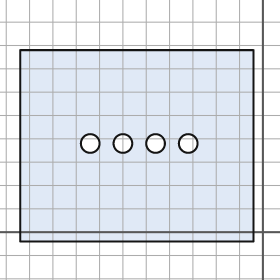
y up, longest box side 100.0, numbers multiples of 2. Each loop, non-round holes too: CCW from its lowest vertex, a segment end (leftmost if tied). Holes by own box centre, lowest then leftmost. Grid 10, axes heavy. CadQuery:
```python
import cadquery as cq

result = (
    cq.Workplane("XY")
    .moveTo(-104.0, -4.0)
    .lineTo(-4.0, -4.0)
    .lineTo(-4.0, 78.0)
    .lineTo(-104.0, 78.0)
    .close()
    .moveTo(-74.0, 38.0)
    .circle(4.0)
    .moveTo(-60.0, 38.0)
    .circle(4.0)
    .moveTo(-46.0, 38.0)
    .circle(4.0)
    .moveTo(-32.0, 38.0)
    .circle(4.0)
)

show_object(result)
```